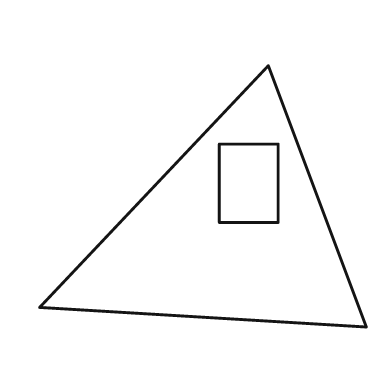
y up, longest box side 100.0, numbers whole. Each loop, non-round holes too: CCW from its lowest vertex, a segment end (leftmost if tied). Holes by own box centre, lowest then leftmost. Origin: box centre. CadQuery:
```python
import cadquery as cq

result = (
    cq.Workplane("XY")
    .moveTo(50.0, -40.0)
    .lineTo(20.0, 40.0)
    .lineTo(-50.0, -34.0)
    .close()
    .moveTo(5.0, -8.0)
    .lineTo(23.0, -8.0)
    .lineTo(23.0, 16.0)
    .lineTo(5.0, 16.0)
    .close()
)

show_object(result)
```